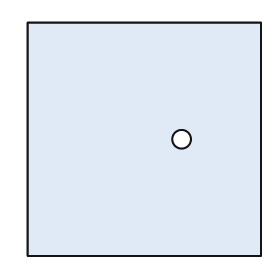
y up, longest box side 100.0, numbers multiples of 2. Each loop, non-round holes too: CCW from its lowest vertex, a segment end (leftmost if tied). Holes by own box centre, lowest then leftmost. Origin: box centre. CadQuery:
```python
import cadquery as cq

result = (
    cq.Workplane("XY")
    .moveTo(-50.0, -50.0)
    .lineTo(50.0, -50.0)
    .lineTo(50.0, 50.0)
    .lineTo(-50.0, 50.0)
    .close()
    .moveTo(16.0, 0.0)
    .circle(4.0)
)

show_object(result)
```